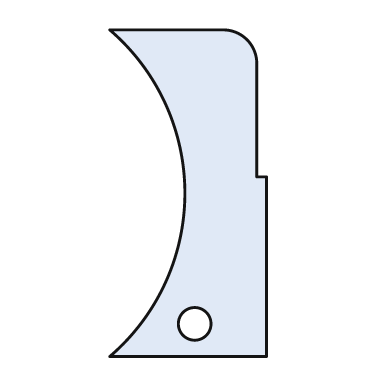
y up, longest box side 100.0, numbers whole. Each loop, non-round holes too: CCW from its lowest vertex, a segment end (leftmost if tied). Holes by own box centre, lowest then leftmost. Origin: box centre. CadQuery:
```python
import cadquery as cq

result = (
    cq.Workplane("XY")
    .moveTo(-24.0, -50.0)
    .lineTo(24.0, -50.0)
    .lineTo(24.0, 5.0)
    .lineTo(21.0, 5.0)
    .lineTo(21.0, 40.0)
    .threePointArc((18.0, 47.0), (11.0, 50.0))
    .lineTo(-24.0, 50.0)
    .threePointArc((-1.0, 0.0), (-24.0, -50.0))
    .close()
    .moveTo(2.0, -40.0)
    .circle(5.0)
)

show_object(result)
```